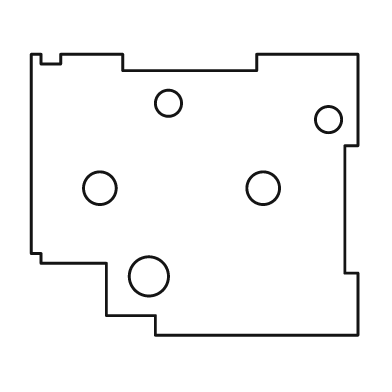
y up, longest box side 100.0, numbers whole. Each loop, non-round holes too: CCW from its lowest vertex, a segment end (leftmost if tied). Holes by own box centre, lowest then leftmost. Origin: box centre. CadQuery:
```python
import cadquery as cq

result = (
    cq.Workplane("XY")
    .moveTo(-12.0, -43.0)
    .lineTo(50.0, -43.0)
    .lineTo(50.0, -24.0)
    .lineTo(46.0, -24.0)
    .lineTo(46.0, 15.0)
    .lineTo(50.0, 15.0)
    .lineTo(50.0, 43.0)
    .lineTo(19.0, 43.0)
    .lineTo(19.0, 38.0)
    .lineTo(-22.0, 38.0)
    .lineTo(-22.0, 43.0)
    .lineTo(-41.0, 43.0)
    .lineTo(-41.0, 40.0)
    .lineTo(-47.0, 40.0)
    .lineTo(-47.0, 43.0)
    .lineTo(-50.0, 43.0)
    .lineTo(-50.0, -18.0)
    .lineTo(-47.0, -18.0)
    .lineTo(-47.0, -21.0)
    .lineTo(-27.0, -21.0)
    .lineTo(-27.0, -37.0)
    .lineTo(-12.0, -37.0)
    .close()
    .moveTo(-14.0, -25.0)
    .circle(6.0)
    .moveTo(-29.0, 2.0)
    .circle(5.0)
    .moveTo(21.0, 2.0)
    .circle(5.0)
    .moveTo(41.0, 23.0)
    .circle(4.0)
    .moveTo(-8.0, 28.0)
    .circle(4.0)
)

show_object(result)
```